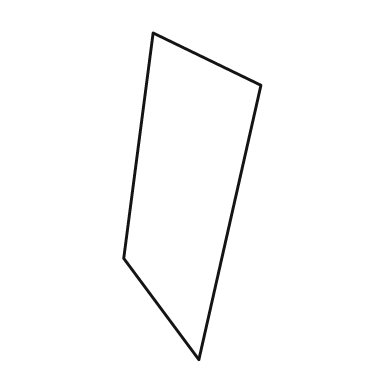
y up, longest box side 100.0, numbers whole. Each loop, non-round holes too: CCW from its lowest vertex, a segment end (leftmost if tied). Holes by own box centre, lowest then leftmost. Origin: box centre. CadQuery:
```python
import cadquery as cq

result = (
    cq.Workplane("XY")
    .moveTo(2.0, -50.0)
    .lineTo(21.0, 34.0)
    .lineTo(-12.0, 50.0)
    .lineTo(-21.0, -19.0)
    .close()
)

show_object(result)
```